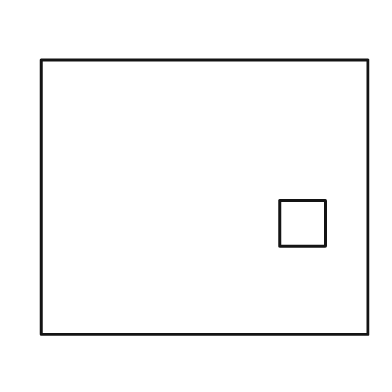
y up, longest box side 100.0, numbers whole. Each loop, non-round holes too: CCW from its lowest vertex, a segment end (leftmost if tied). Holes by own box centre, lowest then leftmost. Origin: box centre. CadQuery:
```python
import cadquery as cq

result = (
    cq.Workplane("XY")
    .moveTo(-50.0, -42.0)
    .lineTo(50.0, -42.0)
    .lineTo(50.0, 42.0)
    .lineTo(-50.0, 42.0)
    .close()
    .moveTo(23.0, -15.0)
    .lineTo(37.0, -15.0)
    .lineTo(37.0, -1.0)
    .lineTo(23.0, -1.0)
    .close()
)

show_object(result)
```